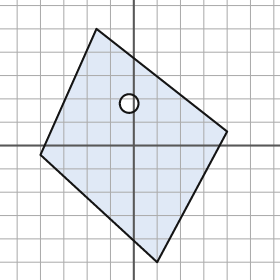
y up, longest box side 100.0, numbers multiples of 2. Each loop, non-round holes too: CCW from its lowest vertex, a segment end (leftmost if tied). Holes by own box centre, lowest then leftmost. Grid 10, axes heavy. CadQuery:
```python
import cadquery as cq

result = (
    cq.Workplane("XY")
    .moveTo(10.0, -50.0)
    .lineTo(40.0, 6.0)
    .lineTo(-16.0, 50.0)
    .lineTo(-40.0, -4.0)
    .close()
    .moveTo(-2.0, 18.0)
    .circle(4.0)
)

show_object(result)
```